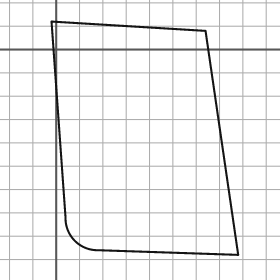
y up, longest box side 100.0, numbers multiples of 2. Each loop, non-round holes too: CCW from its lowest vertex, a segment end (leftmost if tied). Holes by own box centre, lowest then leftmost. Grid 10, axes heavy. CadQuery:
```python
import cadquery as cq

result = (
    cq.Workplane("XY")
    .moveTo(78.0, -88.0)
    .lineTo(64.0, 8.0)
    .lineTo(-2.0, 12.0)
    .lineTo(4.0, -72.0)
    .threePointArc((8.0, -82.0), (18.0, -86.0))
    .close()
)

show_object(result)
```